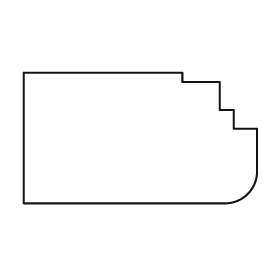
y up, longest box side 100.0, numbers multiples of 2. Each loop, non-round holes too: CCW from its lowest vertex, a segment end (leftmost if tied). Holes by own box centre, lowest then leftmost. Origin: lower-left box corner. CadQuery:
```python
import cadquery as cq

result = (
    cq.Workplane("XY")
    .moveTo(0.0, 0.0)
    .lineTo(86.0, 0.0)
    .threePointArc((96.0, 4.0), (100.0, 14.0))
    .lineTo(100.0, 32.0)
    .lineTo(90.0, 32.0)
    .lineTo(90.0, 40.0)
    .lineTo(84.0, 40.0)
    .lineTo(84.0, 52.0)
    .lineTo(68.0, 52.0)
    .lineTo(68.0, 56.0)
    .lineTo(0.0, 56.0)
    .close()
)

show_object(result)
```